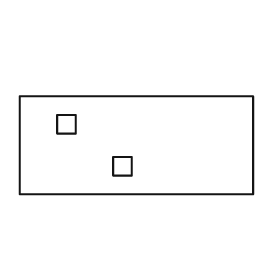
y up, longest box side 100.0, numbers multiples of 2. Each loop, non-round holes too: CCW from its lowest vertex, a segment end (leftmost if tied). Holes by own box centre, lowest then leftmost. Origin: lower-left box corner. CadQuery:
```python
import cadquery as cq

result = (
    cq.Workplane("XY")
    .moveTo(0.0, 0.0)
    .lineTo(100.0, 0.0)
    .lineTo(100.0, 42.0)
    .lineTo(0.0, 42.0)
    .close()
    .moveTo(40.0, 8.0)
    .lineTo(48.0, 8.0)
    .lineTo(48.0, 16.0)
    .lineTo(40.0, 16.0)
    .close()
    .moveTo(16.0, 26.0)
    .lineTo(24.0, 26.0)
    .lineTo(24.0, 34.0)
    .lineTo(16.0, 34.0)
    .close()
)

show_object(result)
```